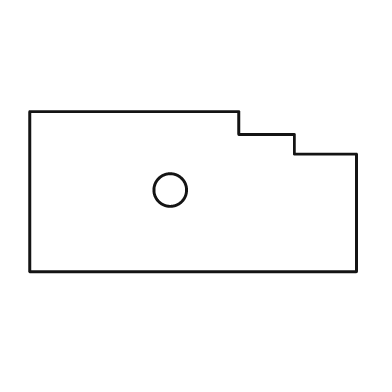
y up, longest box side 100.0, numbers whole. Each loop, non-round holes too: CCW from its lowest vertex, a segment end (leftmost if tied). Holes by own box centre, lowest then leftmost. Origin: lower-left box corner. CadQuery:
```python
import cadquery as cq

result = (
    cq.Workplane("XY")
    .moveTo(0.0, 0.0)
    .lineTo(100.0, 0.0)
    .lineTo(100.0, 36.0)
    .lineTo(81.0, 36.0)
    .lineTo(81.0, 42.0)
    .lineTo(64.0, 42.0)
    .lineTo(64.0, 49.0)
    .lineTo(0.0, 49.0)
    .close()
    .moveTo(43.0, 25.0)
    .circle(5.0)
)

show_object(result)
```